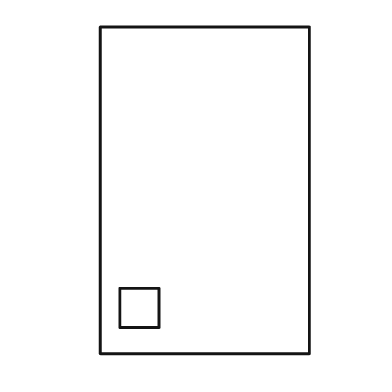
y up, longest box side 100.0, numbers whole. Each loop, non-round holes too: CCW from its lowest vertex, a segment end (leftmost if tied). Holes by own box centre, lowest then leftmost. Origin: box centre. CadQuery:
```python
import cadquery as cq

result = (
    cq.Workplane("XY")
    .moveTo(-32.0, -50.0)
    .lineTo(32.0, -50.0)
    .lineTo(32.0, 50.0)
    .lineTo(-32.0, 50.0)
    .close()
    .moveTo(-26.0, -42.0)
    .lineTo(-14.0, -42.0)
    .lineTo(-14.0, -30.0)
    .lineTo(-26.0, -30.0)
    .close()
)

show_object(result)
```